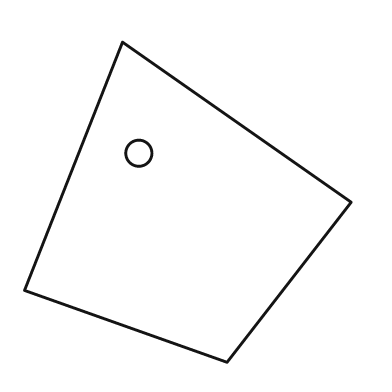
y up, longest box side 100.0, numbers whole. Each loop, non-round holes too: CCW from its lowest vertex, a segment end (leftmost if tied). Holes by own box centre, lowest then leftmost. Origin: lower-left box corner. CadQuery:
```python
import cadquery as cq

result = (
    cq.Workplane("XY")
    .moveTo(62.0, 0.0)
    .lineTo(100.0, 49.0)
    .lineTo(30.0, 98.0)
    .lineTo(0.0, 22.0)
    .close()
    .moveTo(35.0, 64.0)
    .circle(4.0)
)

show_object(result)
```